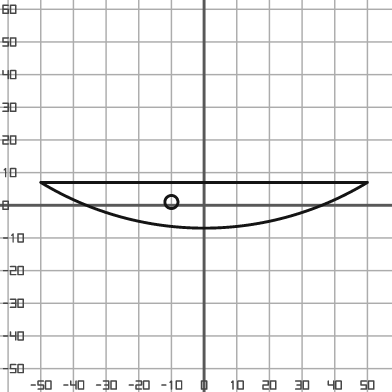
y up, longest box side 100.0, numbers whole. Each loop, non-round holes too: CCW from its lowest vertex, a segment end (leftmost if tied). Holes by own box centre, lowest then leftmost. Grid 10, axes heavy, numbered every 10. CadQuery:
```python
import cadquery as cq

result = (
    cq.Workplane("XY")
    .moveTo(-50.0, 7.0)
    .threePointArc((0.0, -7.0), (50.0, 7.0))
    .close()
    .moveTo(-10.0, 1.0)
    .circle(2.0)
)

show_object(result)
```